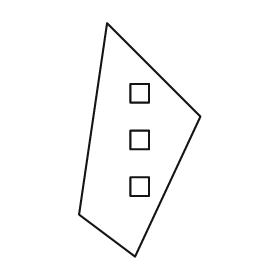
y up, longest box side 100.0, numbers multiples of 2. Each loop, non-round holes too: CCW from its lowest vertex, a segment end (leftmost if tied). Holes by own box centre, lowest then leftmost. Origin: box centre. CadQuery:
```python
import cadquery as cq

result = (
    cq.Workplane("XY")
    .moveTo(-2.0, -50.0)
    .lineTo(26.0, 10.0)
    .lineTo(-14.0, 50.0)
    .lineTo(-26.0, -32.0)
    .close()
    .moveTo(-4.0, -24.0)
    .lineTo(4.0, -24.0)
    .lineTo(4.0, -16.0)
    .lineTo(-4.0, -16.0)
    .close()
    .moveTo(-4.0, -4.0)
    .lineTo(4.0, -4.0)
    .lineTo(4.0, 4.0)
    .lineTo(-4.0, 4.0)
    .close()
    .moveTo(-4.0, 16.0)
    .lineTo(4.0, 16.0)
    .lineTo(4.0, 24.0)
    .lineTo(-4.0, 24.0)
    .close()
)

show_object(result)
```